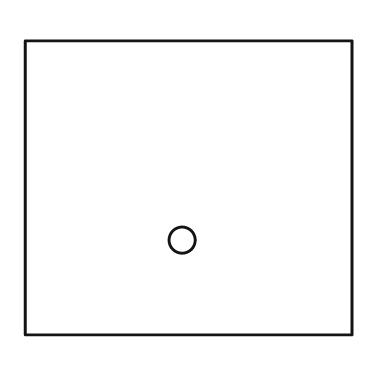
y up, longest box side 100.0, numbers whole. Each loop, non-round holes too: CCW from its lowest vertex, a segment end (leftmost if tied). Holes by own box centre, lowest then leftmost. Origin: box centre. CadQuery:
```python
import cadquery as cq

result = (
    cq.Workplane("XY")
    .moveTo(-50.0, -45.0)
    .lineTo(50.0, -45.0)
    .lineTo(50.0, 45.0)
    .lineTo(-50.0, 45.0)
    .close()
    .moveTo(-2.0, -16.0)
    .circle(4.0)
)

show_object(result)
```